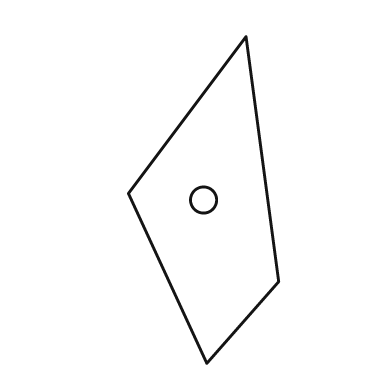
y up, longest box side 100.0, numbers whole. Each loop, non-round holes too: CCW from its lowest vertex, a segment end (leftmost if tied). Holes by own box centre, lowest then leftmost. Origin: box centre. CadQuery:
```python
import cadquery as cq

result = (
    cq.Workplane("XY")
    .moveTo(1.0, -50.0)
    .lineTo(23.0, -25.0)
    .lineTo(13.0, 50.0)
    .lineTo(-23.0, 2.0)
    .close()
    .moveTo(0.0, 0.0)
    .circle(4.0)
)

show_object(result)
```